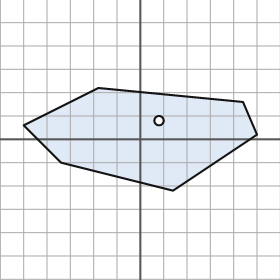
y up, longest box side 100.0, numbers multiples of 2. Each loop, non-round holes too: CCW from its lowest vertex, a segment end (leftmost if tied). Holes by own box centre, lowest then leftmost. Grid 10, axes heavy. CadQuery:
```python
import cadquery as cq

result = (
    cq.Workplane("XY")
    .moveTo(14.0, -22.0)
    .lineTo(50.0, 2.0)
    .lineTo(44.0, 16.0)
    .lineTo(-18.0, 22.0)
    .lineTo(-50.0, 6.0)
    .lineTo(-34.0, -10.0)
    .close()
    .moveTo(8.0, 8.0)
    .circle(2.0)
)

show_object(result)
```